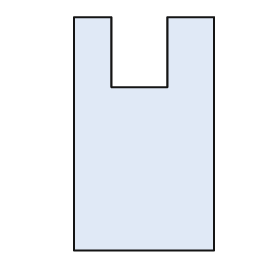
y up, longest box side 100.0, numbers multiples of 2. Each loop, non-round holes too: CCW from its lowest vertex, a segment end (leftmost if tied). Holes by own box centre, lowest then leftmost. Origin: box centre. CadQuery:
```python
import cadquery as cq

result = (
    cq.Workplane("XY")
    .moveTo(-30.0, -50.0)
    .lineTo(30.0, -50.0)
    .lineTo(30.0, 50.0)
    .lineTo(10.0, 50.0)
    .lineTo(10.0, 20.0)
    .lineTo(-14.0, 20.0)
    .lineTo(-14.0, 50.0)
    .lineTo(-30.0, 50.0)
    .close()
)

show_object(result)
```